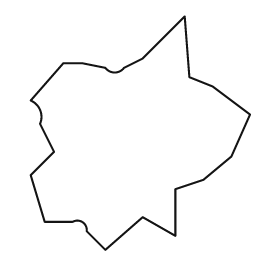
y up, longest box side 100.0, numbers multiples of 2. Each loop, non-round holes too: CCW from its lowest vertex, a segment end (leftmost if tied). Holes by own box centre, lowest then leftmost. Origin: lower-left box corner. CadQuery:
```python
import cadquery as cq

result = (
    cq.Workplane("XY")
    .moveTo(32.0, 0.0)
    .lineTo(48.0, 14.0)
    .lineTo(62.0, 6.0)
    .lineTo(62.0, 26.0)
    .lineTo(74.0, 30.0)
    .lineTo(86.0, 40.0)
    .lineTo(94.0, 58.0)
    .lineTo(78.0, 70.0)
    .lineTo(68.0, 74.0)
    .lineTo(66.0, 100.0)
    .lineTo(48.0, 82.0)
    .lineTo(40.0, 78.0)
    .threePointArc((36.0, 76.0), (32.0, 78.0))
    .lineTo(22.0, 80.0)
    .lineTo(14.0, 80.0)
    .lineTo(0.0, 64.0)
    .threePointArc((4.0, 60.0), (4.0, 54.0))
    .lineTo(10.0, 42.0)
    .lineTo(0.0, 32.0)
    .lineTo(6.0, 12.0)
    .lineTo(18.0, 12.0)
    .threePointArc((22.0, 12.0), (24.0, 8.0))
    .close()
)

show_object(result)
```